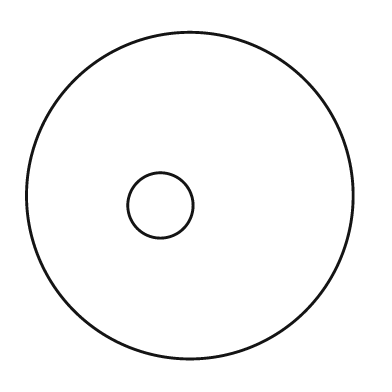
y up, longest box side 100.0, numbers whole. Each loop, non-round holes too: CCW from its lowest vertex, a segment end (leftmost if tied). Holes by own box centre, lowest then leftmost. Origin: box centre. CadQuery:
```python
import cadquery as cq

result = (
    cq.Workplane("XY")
    .moveTo(0.0, 0.0)
    .circle(50.0)
    .moveTo(-9.0, -3.0)
    .circle(10.0)
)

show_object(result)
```